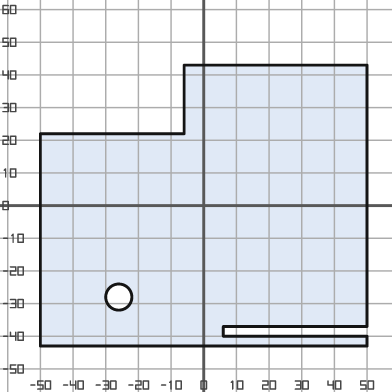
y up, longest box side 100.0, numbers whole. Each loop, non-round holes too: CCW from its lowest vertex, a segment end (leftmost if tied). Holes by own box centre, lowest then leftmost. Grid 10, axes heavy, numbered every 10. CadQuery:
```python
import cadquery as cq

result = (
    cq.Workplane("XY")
    .moveTo(-50.0, -43.0)
    .lineTo(50.0, -43.0)
    .lineTo(50.0, -40.0)
    .lineTo(6.0, -40.0)
    .lineTo(6.0, -37.0)
    .lineTo(50.0, -37.0)
    .lineTo(50.0, 43.0)
    .lineTo(-6.0, 43.0)
    .lineTo(-6.0, 22.0)
    .lineTo(-50.0, 22.0)
    .close()
    .moveTo(-26.0, -28.0)
    .circle(4.0)
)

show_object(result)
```